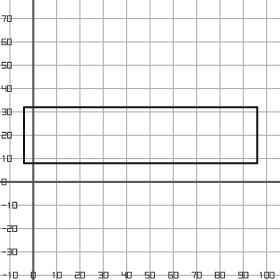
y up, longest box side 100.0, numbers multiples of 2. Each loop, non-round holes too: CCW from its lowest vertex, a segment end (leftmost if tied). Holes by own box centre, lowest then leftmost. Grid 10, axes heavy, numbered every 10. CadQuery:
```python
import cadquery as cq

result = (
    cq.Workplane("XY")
    .moveTo(-4.0, 8.0)
    .lineTo(96.0, 8.0)
    .lineTo(96.0, 32.0)
    .lineTo(-4.0, 32.0)
    .close()
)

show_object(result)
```